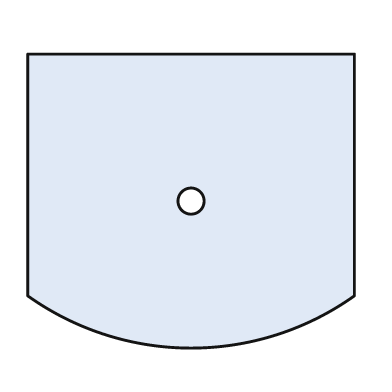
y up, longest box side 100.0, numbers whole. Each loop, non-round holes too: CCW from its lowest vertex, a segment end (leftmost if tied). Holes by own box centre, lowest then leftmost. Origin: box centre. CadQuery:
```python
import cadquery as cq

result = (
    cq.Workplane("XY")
    .moveTo(-50.0, -29.0)
    .threePointArc((0.0, -45.0), (50.0, -29.0))
    .lineTo(50.0, 45.0)
    .lineTo(-50.0, 45.0)
    .close()
    .moveTo(0.0, 0.0)
    .circle(4.0)
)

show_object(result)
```